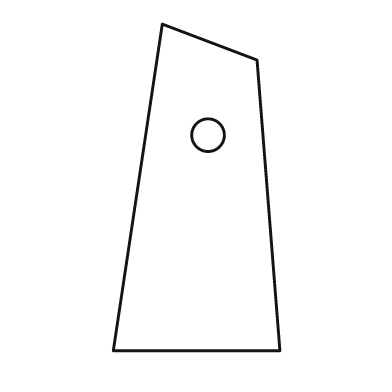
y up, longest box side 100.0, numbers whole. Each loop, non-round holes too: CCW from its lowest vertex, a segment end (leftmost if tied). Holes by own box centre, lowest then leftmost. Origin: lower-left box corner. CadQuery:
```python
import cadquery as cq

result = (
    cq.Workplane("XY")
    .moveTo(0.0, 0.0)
    .lineTo(51.0, 0.0)
    .lineTo(44.0, 89.0)
    .lineTo(15.0, 100.0)
    .close()
    .moveTo(29.0, 66.0)
    .circle(5.0)
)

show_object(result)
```